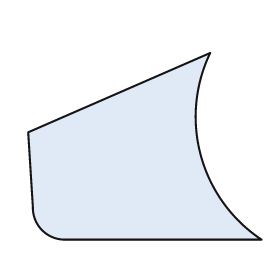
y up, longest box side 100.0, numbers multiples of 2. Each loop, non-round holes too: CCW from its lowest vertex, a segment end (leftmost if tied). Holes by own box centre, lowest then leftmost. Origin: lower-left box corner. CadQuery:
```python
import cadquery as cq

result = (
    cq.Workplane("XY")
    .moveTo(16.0, 0.0)
    .lineTo(100.0, 0.0)
    .threePointArc((74.0, 36.0), (78.0, 80.0))
    .lineTo(0.0, 46.0)
    .lineTo(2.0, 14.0)
    .threePointArc((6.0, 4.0), (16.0, 0.0))
    .close()
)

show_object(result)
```